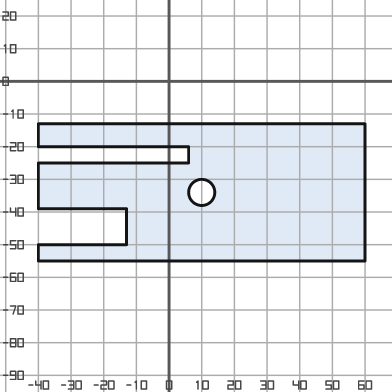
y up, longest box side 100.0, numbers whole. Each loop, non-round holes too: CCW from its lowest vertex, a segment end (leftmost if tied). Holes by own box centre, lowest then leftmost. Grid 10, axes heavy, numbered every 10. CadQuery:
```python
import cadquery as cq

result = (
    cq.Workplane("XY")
    .moveTo(-40.0, -55.0)
    .lineTo(60.0, -55.0)
    .lineTo(60.0, -13.0)
    .lineTo(-40.0, -13.0)
    .lineTo(-40.0, -20.0)
    .lineTo(6.0, -20.0)
    .lineTo(6.0, -25.0)
    .lineTo(-40.0, -25.0)
    .lineTo(-40.0, -39.0)
    .lineTo(-13.0, -39.0)
    .lineTo(-13.0, -50.0)
    .lineTo(-40.0, -50.0)
    .close()
    .moveTo(10.0, -34.0)
    .circle(4.0)
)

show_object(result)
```